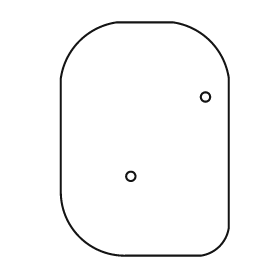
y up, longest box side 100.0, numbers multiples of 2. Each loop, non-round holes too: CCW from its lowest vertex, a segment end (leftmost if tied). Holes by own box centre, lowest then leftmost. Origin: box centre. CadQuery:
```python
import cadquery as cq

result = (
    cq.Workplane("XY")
    .moveTo(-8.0, -50.0)
    .lineTo(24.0, -50.0)
    .threePointArc((32.0, -46.0), (36.0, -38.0))
    .lineTo(36.0, 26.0)
    .threePointArc((28.0, 42.0), (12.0, 50.0))
    .lineTo(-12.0, 50.0)
    .threePointArc((-28.0, 42.0), (-36.0, 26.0))
    .lineTo(-36.0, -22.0)
    .threePointArc((-28.0, -42.0), (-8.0, -50.0))
    .close()
    .moveTo(-6.0, -16.0)
    .circle(2.0)
    .moveTo(26.0, 18.0)
    .circle(2.0)
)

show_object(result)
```